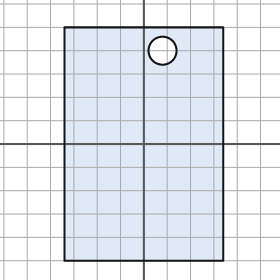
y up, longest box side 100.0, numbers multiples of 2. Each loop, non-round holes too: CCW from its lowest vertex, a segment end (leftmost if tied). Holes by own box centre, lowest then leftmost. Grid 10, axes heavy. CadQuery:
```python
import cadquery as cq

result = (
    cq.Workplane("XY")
    .moveTo(-34.0, -50.0)
    .lineTo(34.0, -50.0)
    .lineTo(34.0, 50.0)
    .lineTo(-34.0, 50.0)
    .close()
    .moveTo(8.0, 40.0)
    .circle(6.0)
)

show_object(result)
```